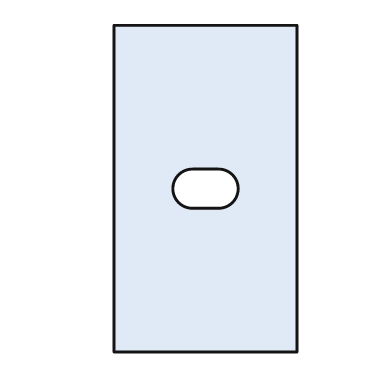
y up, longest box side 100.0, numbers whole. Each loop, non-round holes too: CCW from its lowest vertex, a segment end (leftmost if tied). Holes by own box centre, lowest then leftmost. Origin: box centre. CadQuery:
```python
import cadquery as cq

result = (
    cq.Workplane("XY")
    .moveTo(-28.0, -50.0)
    .lineTo(28.0, -50.0)
    .lineTo(28.0, 50.0)
    .lineTo(-28.0, 50.0)
    .close()
    .moveTo(-4.0, -6.0)
    .lineTo(4.0, -6.0)
    .threePointArc((10.0, 0.0), (4.0, 6.0))
    .lineTo(-4.0, 6.0)
    .threePointArc((-10.0, 0.0), (-4.0, -6.0))
    .close()
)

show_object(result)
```